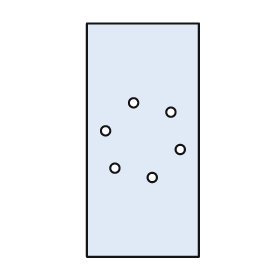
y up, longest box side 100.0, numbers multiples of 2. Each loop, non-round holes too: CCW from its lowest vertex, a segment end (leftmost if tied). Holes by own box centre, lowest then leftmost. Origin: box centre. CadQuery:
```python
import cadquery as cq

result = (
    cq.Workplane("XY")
    .moveTo(-24.0, -50.0)
    .lineTo(24.0, -50.0)
    .lineTo(24.0, 50.0)
    .lineTo(-24.0, 50.0)
    .close()
    .moveTo(4.0, -16.0)
    .circle(2.0)
    .moveTo(-12.0, -12.0)
    .circle(2.0)
    .moveTo(16.0, -4.0)
    .circle(2.0)
    .moveTo(-16.0, 4.0)
    .circle(2.0)
    .moveTo(12.0, 12.0)
    .circle(2.0)
    .moveTo(-4.0, 16.0)
    .circle(2.0)
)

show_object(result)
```